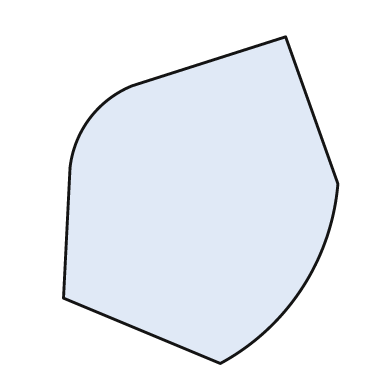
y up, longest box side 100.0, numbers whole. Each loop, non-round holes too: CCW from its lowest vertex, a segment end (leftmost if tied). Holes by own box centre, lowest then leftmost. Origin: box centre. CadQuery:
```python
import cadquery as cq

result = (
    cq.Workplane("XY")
    .moveTo(6.0, -50.0)
    .threePointArc((31.0, -27.0), (42.0, 5.0))
    .lineTo(26.0, 50.0)
    .lineTo(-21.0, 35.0)
    .threePointArc((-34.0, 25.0), (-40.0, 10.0))
    .lineTo(-42.0, -30.0)
    .close()
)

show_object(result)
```